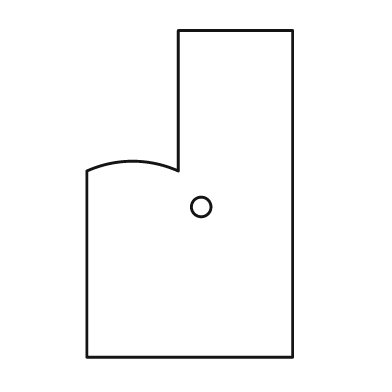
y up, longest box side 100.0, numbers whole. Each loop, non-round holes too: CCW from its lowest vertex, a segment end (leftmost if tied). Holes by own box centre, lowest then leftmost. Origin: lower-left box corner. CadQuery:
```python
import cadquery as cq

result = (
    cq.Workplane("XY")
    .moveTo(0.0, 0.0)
    .lineTo(63.0, 0.0)
    .lineTo(63.0, 100.0)
    .lineTo(28.0, 100.0)
    .lineTo(28.0, 57.0)
    .threePointArc((14.0, 60.0), (0.0, 57.0))
    .close()
    .moveTo(35.0, 46.0)
    .circle(3.0)
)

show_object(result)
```